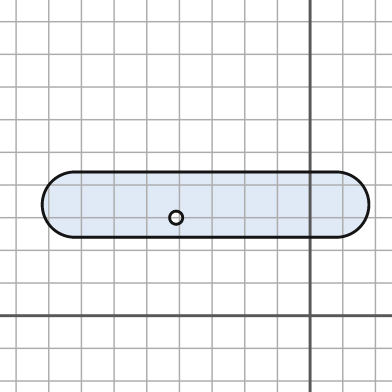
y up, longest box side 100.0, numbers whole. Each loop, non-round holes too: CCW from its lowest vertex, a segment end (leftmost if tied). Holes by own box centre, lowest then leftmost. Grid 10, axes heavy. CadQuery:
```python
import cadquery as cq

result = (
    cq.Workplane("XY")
    .moveTo(-72.0, 24.0)
    .lineTo(8.0, 24.0)
    .threePointArc((18.0, 34.0), (8.0, 44.0))
    .lineTo(-72.0, 44.0)
    .threePointArc((-82.0, 34.0), (-72.0, 24.0))
    .close()
    .moveTo(-41.0, 30.0)
    .circle(2.0)
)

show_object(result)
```